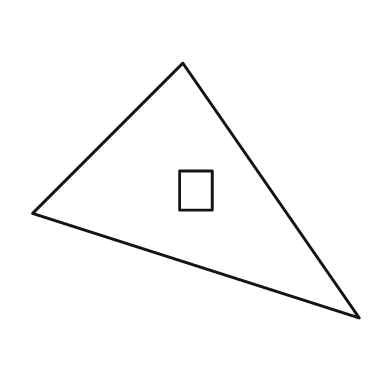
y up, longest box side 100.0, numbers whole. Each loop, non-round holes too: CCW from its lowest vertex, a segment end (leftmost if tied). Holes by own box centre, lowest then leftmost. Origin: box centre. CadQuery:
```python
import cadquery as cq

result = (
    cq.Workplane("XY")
    .moveTo(50.0, -39.0)
    .lineTo(-4.0, 39.0)
    .lineTo(-50.0, -7.0)
    .close()
    .moveTo(-5.0, -6.0)
    .lineTo(5.0, -6.0)
    .lineTo(5.0, 6.0)
    .lineTo(-5.0, 6.0)
    .close()
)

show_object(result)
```